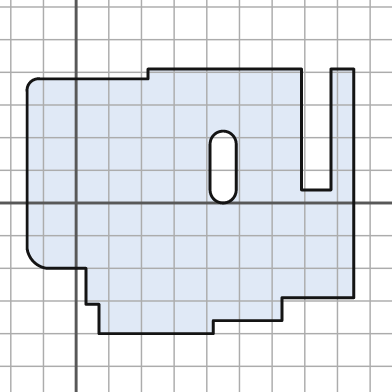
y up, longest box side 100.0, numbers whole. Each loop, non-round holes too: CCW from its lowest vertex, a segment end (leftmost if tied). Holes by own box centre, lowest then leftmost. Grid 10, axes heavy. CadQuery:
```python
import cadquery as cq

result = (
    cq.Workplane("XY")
    .moveTo(7.0, -40.0)
    .lineTo(42.0, -40.0)
    .lineTo(42.0, -36.0)
    .lineTo(63.0, -36.0)
    .lineTo(63.0, -29.0)
    .lineTo(85.0, -29.0)
    .lineTo(85.0, 41.0)
    .lineTo(78.0, 41.0)
    .lineTo(78.0, 4.0)
    .lineTo(69.0, 4.0)
    .lineTo(69.0, 41.0)
    .lineTo(22.0, 41.0)
    .lineTo(22.0, 38.0)
    .lineTo(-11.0, 38.0)
    .threePointArc((-14.0, 37.0), (-15.0, 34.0))
    .lineTo(-15.0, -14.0)
    .threePointArc((-13.0, -18.0), (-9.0, -20.0))
    .lineTo(3.0, -20.0)
    .lineTo(3.0, -31.0)
    .lineTo(7.0, -31.0)
    .close()
    .moveTo(41.0, 4.0)
    .threePointArc((45.0, 0.0), (49.0, 4.0))
    .lineTo(49.0, 18.0)
    .threePointArc((45.0, 22.0), (41.0, 18.0))
    .close()
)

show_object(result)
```